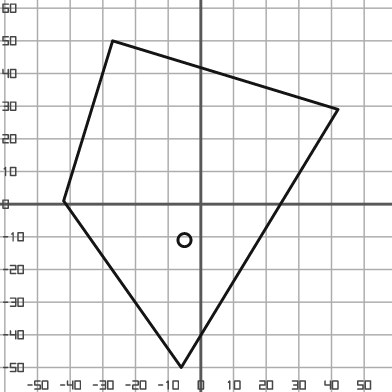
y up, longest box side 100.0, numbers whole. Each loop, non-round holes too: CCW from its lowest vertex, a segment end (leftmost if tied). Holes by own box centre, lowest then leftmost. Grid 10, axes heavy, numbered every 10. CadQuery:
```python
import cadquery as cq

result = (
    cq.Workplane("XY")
    .moveTo(-6.0, -50.0)
    .lineTo(42.0, 29.0)
    .lineTo(-27.0, 50.0)
    .lineTo(-42.0, 1.0)
    .close()
    .moveTo(-5.0, -11.0)
    .circle(2.0)
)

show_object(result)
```